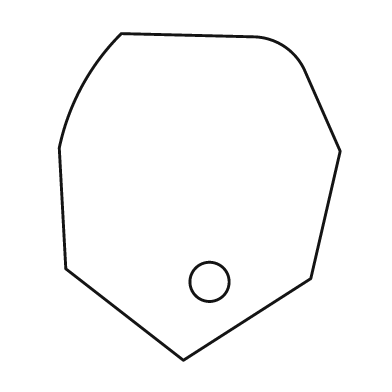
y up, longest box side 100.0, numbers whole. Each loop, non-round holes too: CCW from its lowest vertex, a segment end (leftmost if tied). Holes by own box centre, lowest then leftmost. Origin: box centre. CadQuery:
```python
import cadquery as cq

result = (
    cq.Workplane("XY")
    .moveTo(-5.0, -50.0)
    .lineTo(34.0, -25.0)
    .lineTo(43.0, 14.0)
    .lineTo(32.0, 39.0)
    .threePointArc((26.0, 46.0), (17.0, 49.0))
    .lineTo(-24.0, 50.0)
    .threePointArc((-36.0, 34.0), (-43.0, 15.0))
    .lineTo(-41.0, -22.0)
    .close()
    .moveTo(3.0, -26.0)
    .circle(6.0)
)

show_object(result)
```